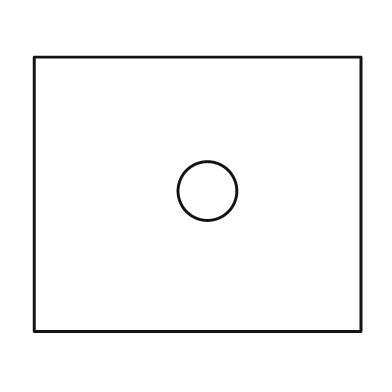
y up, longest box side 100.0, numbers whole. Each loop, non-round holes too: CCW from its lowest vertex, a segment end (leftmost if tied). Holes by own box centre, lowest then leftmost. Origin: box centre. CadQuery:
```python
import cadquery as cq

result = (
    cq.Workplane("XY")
    .moveTo(-50.0, -42.0)
    .lineTo(50.0, -42.0)
    .lineTo(50.0, 42.0)
    .lineTo(-50.0, 42.0)
    .close()
    .moveTo(3.0, 1.0)
    .circle(9.0)
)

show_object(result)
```